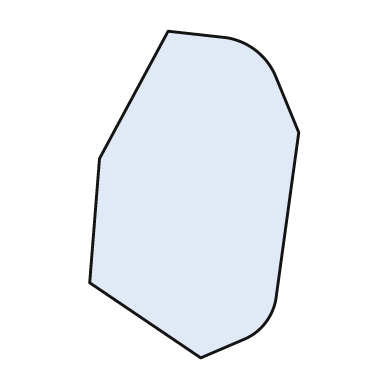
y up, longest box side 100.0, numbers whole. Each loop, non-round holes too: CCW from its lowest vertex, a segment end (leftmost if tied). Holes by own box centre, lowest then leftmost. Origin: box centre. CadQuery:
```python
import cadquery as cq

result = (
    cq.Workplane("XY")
    .moveTo(2.0, -50.0)
    .lineTo(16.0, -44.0)
    .threePointArc((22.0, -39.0), (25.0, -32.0))
    .lineTo(32.0, 19.0)
    .lineTo(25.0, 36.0)
    .threePointArc((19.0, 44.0), (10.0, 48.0))
    .lineTo(-8.0, 50.0)
    .lineTo(-29.0, 11.0)
    .lineTo(-32.0, -27.0)
    .close()
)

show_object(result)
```